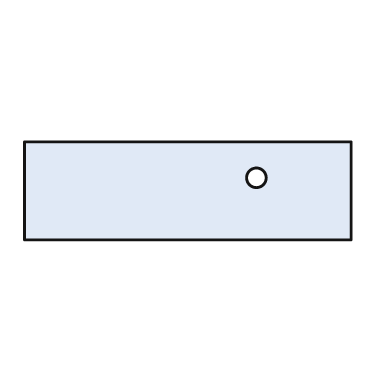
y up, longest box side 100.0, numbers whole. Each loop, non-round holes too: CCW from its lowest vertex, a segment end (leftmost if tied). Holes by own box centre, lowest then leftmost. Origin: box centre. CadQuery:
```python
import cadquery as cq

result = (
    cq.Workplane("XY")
    .moveTo(-50.0, -15.0)
    .lineTo(50.0, -15.0)
    .lineTo(50.0, 15.0)
    .lineTo(-50.0, 15.0)
    .close()
    .moveTo(21.0, 4.0)
    .circle(3.0)
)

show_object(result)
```